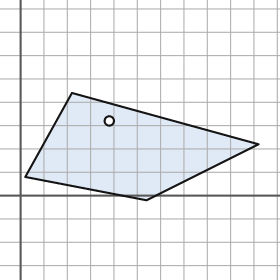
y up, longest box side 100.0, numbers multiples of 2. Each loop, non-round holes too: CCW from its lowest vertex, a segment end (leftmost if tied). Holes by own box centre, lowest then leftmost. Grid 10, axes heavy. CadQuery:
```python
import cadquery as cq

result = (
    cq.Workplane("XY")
    .moveTo(54.0, -2.0)
    .lineTo(102.0, 22.0)
    .lineTo(22.0, 44.0)
    .lineTo(2.0, 8.0)
    .close()
    .moveTo(38.0, 32.0)
    .circle(2.0)
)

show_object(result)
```